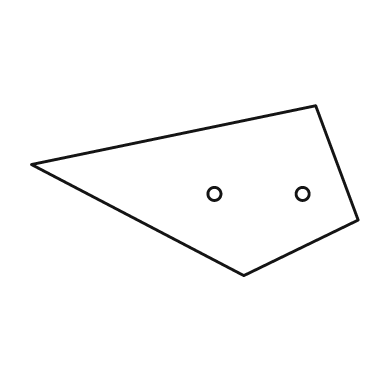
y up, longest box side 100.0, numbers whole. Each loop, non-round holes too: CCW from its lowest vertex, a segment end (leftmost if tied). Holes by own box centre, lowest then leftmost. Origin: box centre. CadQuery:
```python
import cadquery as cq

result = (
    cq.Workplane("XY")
    .moveTo(15.0, -26.0)
    .lineTo(50.0, -9.0)
    .lineTo(37.0, 26.0)
    .lineTo(-50.0, 8.0)
    .close()
    .moveTo(6.0, -1.0)
    .circle(2.0)
    .moveTo(33.0, -1.0)
    .circle(2.0)
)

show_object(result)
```